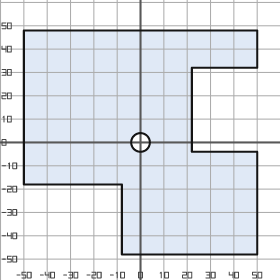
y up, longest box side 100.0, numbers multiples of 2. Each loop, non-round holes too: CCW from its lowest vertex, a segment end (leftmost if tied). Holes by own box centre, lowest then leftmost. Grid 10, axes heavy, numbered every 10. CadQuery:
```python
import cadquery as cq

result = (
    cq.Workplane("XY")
    .moveTo(-8.0, -48.0)
    .lineTo(50.0, -48.0)
    .lineTo(50.0, -4.0)
    .lineTo(22.0, -4.0)
    .lineTo(22.0, 32.0)
    .lineTo(50.0, 32.0)
    .lineTo(50.0, 48.0)
    .lineTo(-50.0, 48.0)
    .lineTo(-50.0, -18.0)
    .lineTo(-8.0, -18.0)
    .close()
    .moveTo(0.0, 0.0)
    .circle(4.0)
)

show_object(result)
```